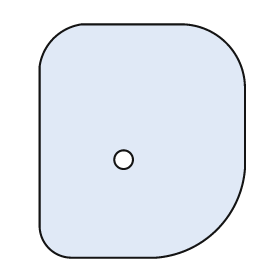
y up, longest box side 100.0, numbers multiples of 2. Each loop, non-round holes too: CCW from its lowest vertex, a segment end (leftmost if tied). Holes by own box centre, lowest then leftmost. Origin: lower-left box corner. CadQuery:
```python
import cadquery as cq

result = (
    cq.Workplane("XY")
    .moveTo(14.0, 0.0)
    .lineTo(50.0, 0.0)
    .threePointArc((76.0, 12.0), (88.0, 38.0))
    .lineTo(88.0, 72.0)
    .threePointArc((80.0, 92.0), (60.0, 100.0))
    .lineTo(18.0, 100.0)
    .threePointArc((6.0, 94.0), (0.0, 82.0))
    .lineTo(0.0, 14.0)
    .threePointArc((4.0, 4.0), (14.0, 0.0))
    .close()
    .moveTo(36.0, 42.0)
    .circle(4.0)
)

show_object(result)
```